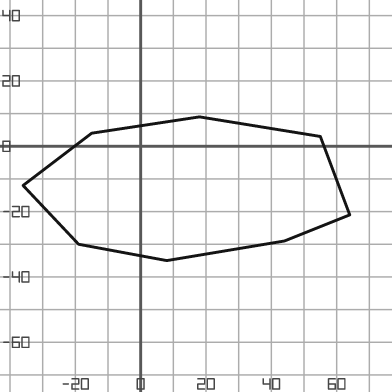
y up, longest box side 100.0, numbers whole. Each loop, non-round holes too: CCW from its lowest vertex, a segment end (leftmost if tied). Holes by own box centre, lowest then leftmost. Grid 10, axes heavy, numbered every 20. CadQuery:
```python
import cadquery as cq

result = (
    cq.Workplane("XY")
    .moveTo(8.0, -35.0)
    .lineTo(44.0, -29.0)
    .lineTo(64.0, -21.0)
    .lineTo(55.0, 3.0)
    .lineTo(18.0, 9.0)
    .lineTo(-15.0, 4.0)
    .lineTo(-36.0, -12.0)
    .lineTo(-19.0, -30.0)
    .close()
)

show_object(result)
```